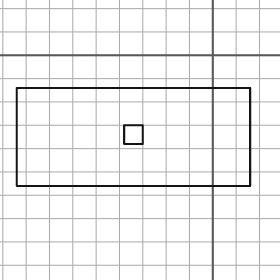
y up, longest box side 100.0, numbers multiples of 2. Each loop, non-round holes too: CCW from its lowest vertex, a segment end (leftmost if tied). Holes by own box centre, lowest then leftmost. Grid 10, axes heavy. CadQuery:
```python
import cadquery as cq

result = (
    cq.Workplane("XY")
    .moveTo(-84.0, -56.0)
    .lineTo(16.0, -56.0)
    .lineTo(16.0, -14.0)
    .lineTo(-84.0, -14.0)
    .close()
    .moveTo(-38.0, -38.0)
    .lineTo(-30.0, -38.0)
    .lineTo(-30.0, -30.0)
    .lineTo(-38.0, -30.0)
    .close()
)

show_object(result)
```